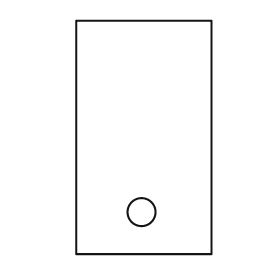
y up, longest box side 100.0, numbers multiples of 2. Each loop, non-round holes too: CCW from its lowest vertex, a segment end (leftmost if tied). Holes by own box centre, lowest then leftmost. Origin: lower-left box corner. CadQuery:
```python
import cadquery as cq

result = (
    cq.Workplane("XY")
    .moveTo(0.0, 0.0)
    .lineTo(58.0, 0.0)
    .lineTo(58.0, 100.0)
    .lineTo(0.0, 100.0)
    .close()
    .moveTo(28.0, 18.0)
    .circle(6.0)
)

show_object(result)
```